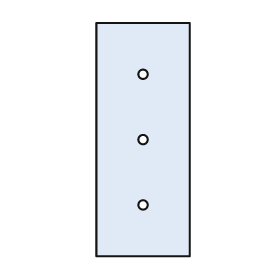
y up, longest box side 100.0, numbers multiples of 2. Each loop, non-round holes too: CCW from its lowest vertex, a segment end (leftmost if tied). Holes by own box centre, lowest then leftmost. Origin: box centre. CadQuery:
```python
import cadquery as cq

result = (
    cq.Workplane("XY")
    .moveTo(-20.0, -50.0)
    .lineTo(20.0, -50.0)
    .lineTo(20.0, 50.0)
    .lineTo(-20.0, 50.0)
    .close()
    .moveTo(0.0, -28.0)
    .circle(2.0)
    .moveTo(0.0, 0.0)
    .circle(2.0)
    .moveTo(0.0, 28.0)
    .circle(2.0)
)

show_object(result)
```